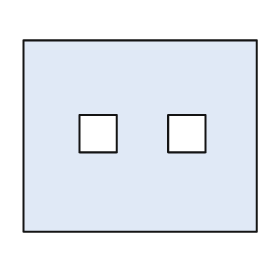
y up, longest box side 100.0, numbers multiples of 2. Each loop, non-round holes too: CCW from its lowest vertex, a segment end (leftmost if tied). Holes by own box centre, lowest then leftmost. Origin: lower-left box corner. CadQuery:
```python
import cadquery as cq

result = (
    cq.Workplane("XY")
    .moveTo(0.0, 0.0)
    .lineTo(100.0, 0.0)
    .lineTo(100.0, 82.0)
    .lineTo(0.0, 82.0)
    .close()
    .moveTo(24.0, 34.0)
    .lineTo(40.0, 34.0)
    .lineTo(40.0, 50.0)
    .lineTo(24.0, 50.0)
    .close()
    .moveTo(62.0, 34.0)
    .lineTo(78.0, 34.0)
    .lineTo(78.0, 50.0)
    .lineTo(62.0, 50.0)
    .close()
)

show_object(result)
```